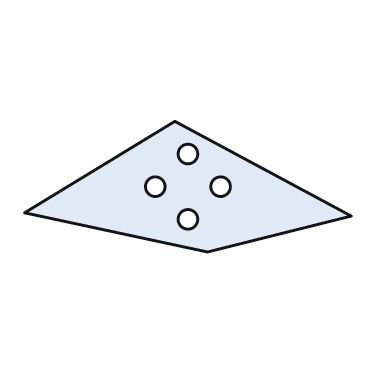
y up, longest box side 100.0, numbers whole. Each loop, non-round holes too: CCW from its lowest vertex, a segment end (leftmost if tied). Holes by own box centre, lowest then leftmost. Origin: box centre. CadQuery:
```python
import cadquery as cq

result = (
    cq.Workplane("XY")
    .moveTo(6.0, -20.0)
    .lineTo(50.0, -9.0)
    .lineTo(-4.0, 20.0)
    .lineTo(-50.0, -8.0)
    .close()
    .moveTo(0.0, -10.0)
    .circle(3.0)
    .moveTo(-10.0, 0.0)
    .circle(3.0)
    .moveTo(10.0, 0.0)
    .circle(3.0)
    .moveTo(0.0, 10.0)
    .circle(3.0)
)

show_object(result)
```